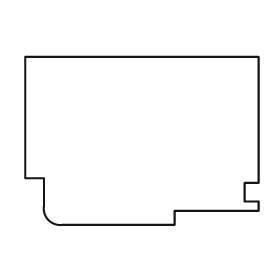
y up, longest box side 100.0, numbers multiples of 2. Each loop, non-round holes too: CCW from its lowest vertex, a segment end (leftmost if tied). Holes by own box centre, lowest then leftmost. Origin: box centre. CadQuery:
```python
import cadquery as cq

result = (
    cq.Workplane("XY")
    .moveTo(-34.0, -36.0)
    .lineTo(14.0, -36.0)
    .lineTo(14.0, -30.0)
    .lineTo(50.0, -30.0)
    .lineTo(50.0, -26.0)
    .lineTo(44.0, -26.0)
    .lineTo(44.0, -18.0)
    .lineTo(50.0, -18.0)
    .lineTo(50.0, 36.0)
    .lineTo(-50.0, 36.0)
    .lineTo(-50.0, -16.0)
    .lineTo(-42.0, -16.0)
    .lineTo(-42.0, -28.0)
    .threePointArc((-40.0, -34.0), (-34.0, -36.0))
    .close()
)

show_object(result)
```